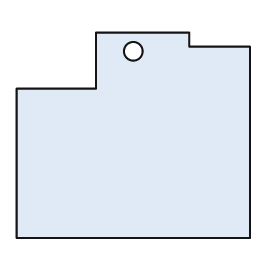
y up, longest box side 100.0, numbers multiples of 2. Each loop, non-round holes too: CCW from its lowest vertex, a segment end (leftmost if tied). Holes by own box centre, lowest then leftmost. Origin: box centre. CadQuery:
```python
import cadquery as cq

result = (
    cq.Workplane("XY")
    .moveTo(-50.0, -44.0)
    .lineTo(50.0, -44.0)
    .lineTo(50.0, 38.0)
    .lineTo(24.0, 38.0)
    .lineTo(24.0, 44.0)
    .lineTo(-16.0, 44.0)
    .lineTo(-16.0, 20.0)
    .lineTo(-50.0, 20.0)
    .close()
    .moveTo(0.0, 36.0)
    .circle(4.0)
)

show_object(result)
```